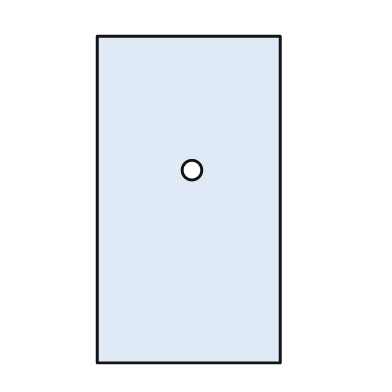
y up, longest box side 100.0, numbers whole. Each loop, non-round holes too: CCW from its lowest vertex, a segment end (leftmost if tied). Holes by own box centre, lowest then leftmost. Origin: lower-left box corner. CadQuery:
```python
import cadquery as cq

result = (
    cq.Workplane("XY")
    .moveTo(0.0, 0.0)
    .lineTo(56.0, 0.0)
    .lineTo(56.0, 100.0)
    .lineTo(0.0, 100.0)
    .close()
    .moveTo(29.0, 59.0)
    .circle(3.0)
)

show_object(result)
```